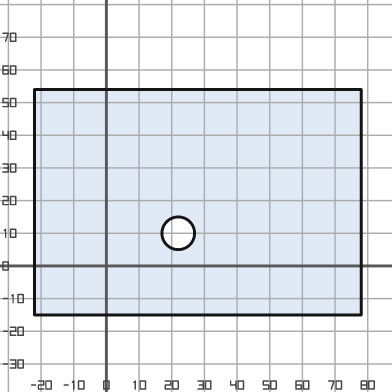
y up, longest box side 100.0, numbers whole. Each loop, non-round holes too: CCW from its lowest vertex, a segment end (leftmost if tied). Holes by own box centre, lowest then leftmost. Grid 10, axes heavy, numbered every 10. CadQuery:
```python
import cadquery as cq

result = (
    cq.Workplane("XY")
    .moveTo(-22.0, -15.0)
    .lineTo(78.0, -15.0)
    .lineTo(78.0, 54.0)
    .lineTo(-22.0, 54.0)
    .close()
    .moveTo(22.0, 10.0)
    .circle(5.0)
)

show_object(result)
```